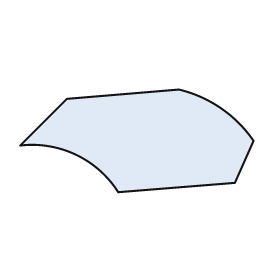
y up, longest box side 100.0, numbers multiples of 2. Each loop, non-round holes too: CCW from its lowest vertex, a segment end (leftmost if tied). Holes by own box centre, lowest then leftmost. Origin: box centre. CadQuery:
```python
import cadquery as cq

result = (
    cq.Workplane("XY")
    .moveTo(-8.0, -22.0)
    .lineTo(42.0, -18.0)
    .lineTo(50.0, 0.0)
    .threePointArc((36.0, 14.0), (18.0, 22.0))
    .lineTo(-30.0, 18.0)
    .lineTo(-50.0, -2.0)
    .threePointArc((-26.0, -6.0), (-8.0, -22.0))
    .close()
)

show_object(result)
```